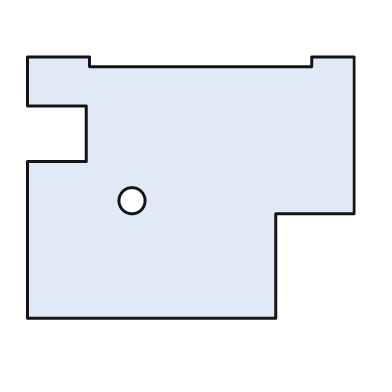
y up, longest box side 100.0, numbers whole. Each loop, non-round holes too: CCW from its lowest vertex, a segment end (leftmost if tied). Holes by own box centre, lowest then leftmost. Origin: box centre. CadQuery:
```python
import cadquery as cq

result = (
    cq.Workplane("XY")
    .moveTo(-50.0, -40.0)
    .lineTo(26.0, -40.0)
    .lineTo(26.0, -8.0)
    .lineTo(50.0, -8.0)
    .lineTo(50.0, 40.0)
    .lineTo(37.0, 40.0)
    .lineTo(37.0, 37.0)
    .lineTo(-31.0, 37.0)
    .lineTo(-31.0, 40.0)
    .lineTo(-50.0, 40.0)
    .lineTo(-50.0, 25.0)
    .lineTo(-32.0, 25.0)
    .lineTo(-32.0, 8.0)
    .lineTo(-50.0, 8.0)
    .close()
    .moveTo(-18.0, -4.0)
    .circle(4.0)
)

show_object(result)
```